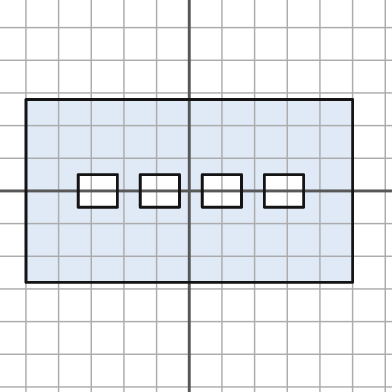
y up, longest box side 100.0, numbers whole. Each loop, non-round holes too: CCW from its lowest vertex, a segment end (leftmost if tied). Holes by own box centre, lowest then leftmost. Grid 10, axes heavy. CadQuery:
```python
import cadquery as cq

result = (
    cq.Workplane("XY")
    .moveTo(-50.0, -28.0)
    .lineTo(50.0, -28.0)
    .lineTo(50.0, 28.0)
    .lineTo(-50.0, 28.0)
    .close()
    .moveTo(-34.0, -5.0)
    .lineTo(-22.0, -5.0)
    .lineTo(-22.0, 5.0)
    .lineTo(-34.0, 5.0)
    .close()
    .moveTo(-15.0, -5.0)
    .lineTo(-3.0, -5.0)
    .lineTo(-3.0, 5.0)
    .lineTo(-15.0, 5.0)
    .close()
    .moveTo(4.0, -5.0)
    .lineTo(16.0, -5.0)
    .lineTo(16.0, 5.0)
    .lineTo(4.0, 5.0)
    .close()
    .moveTo(23.0, -5.0)
    .lineTo(35.0, -5.0)
    .lineTo(35.0, 5.0)
    .lineTo(23.0, 5.0)
    .close()
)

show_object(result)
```